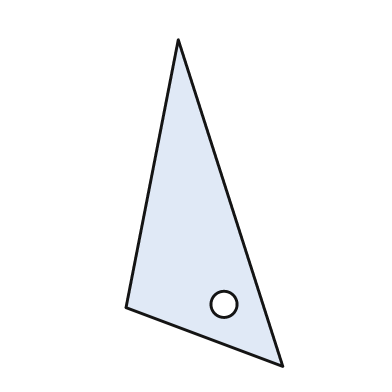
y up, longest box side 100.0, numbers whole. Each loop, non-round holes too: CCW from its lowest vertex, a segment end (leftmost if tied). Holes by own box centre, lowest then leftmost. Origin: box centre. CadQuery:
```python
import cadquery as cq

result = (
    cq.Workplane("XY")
    .moveTo(24.0, -50.0)
    .lineTo(-8.0, 50.0)
    .lineTo(-24.0, -32.0)
    .close()
    .moveTo(6.0, -31.0)
    .circle(4.0)
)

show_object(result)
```